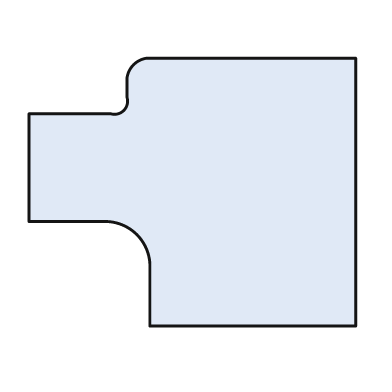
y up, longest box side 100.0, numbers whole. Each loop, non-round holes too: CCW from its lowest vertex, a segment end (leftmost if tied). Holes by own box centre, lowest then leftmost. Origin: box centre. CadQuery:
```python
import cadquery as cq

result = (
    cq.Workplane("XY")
    .moveTo(-13.0, -41.0)
    .lineTo(50.0, -41.0)
    .lineTo(50.0, 41.0)
    .lineTo(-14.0, 41.0)
    .threePointArc((-18.0, 39.0), (-20.0, 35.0))
    .lineTo(-20.0, 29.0)
    .threePointArc((-21.0, 25.0), (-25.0, 24.0))
    .lineTo(-50.0, 24.0)
    .lineTo(-50.0, -9.0)
    .lineTo(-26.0, -9.0)
    .threePointArc((-17.0, -13.0), (-13.0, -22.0))
    .close()
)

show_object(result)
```